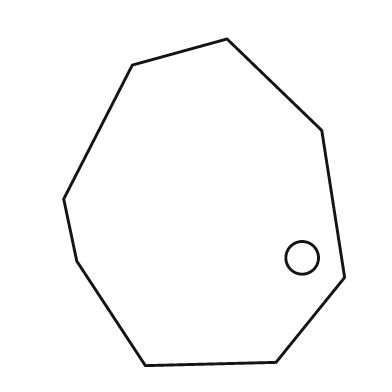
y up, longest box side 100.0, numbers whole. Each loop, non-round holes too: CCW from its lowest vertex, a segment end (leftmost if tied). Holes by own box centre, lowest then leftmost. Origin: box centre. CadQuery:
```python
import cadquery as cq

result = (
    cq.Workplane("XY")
    .moveTo(-18.0, -50.0)
    .lineTo(22.0, -49.0)
    .lineTo(43.0, -23.0)
    .lineTo(36.0, 22.0)
    .lineTo(7.0, 50.0)
    .lineTo(-22.0, 42.0)
    .lineTo(-43.0, 1.0)
    .lineTo(-39.0, -18.0)
    .close()
    .moveTo(30.0, -17.0)
    .circle(5.0)
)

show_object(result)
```